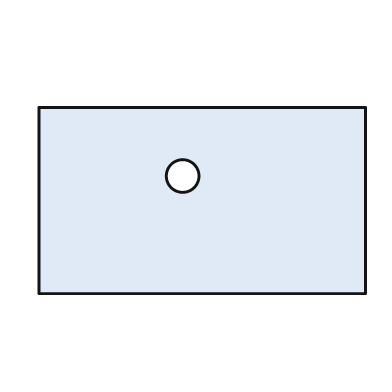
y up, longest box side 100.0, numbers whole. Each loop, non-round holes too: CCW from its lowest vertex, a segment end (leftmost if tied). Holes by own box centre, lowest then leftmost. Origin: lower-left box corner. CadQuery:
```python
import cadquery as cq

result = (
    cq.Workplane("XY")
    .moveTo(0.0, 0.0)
    .lineTo(100.0, 0.0)
    .lineTo(100.0, 57.0)
    .lineTo(0.0, 57.0)
    .close()
    .moveTo(44.0, 36.0)
    .circle(5.0)
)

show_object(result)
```